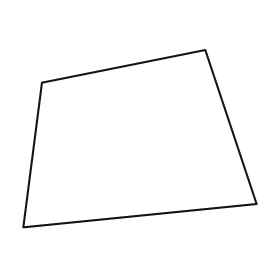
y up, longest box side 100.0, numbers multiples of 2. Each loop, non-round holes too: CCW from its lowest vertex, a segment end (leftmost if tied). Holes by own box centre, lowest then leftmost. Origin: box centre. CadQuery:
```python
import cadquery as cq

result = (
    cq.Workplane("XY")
    .moveTo(-50.0, -38.0)
    .lineTo(50.0, -28.0)
    .lineTo(28.0, 38.0)
    .lineTo(-42.0, 24.0)
    .close()
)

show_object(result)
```